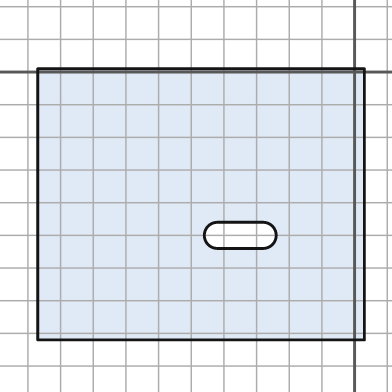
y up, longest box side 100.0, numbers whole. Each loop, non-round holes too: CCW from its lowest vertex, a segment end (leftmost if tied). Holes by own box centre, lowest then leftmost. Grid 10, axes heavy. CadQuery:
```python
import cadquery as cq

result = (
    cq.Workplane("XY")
    .moveTo(-97.0, -82.0)
    .lineTo(3.0, -82.0)
    .lineTo(3.0, 1.0)
    .lineTo(-97.0, 1.0)
    .close()
    .moveTo(-42.0, -54.0)
    .lineTo(-28.0, -54.0)
    .threePointArc((-24.0, -50.0), (-28.0, -46.0))
    .lineTo(-42.0, -46.0)
    .threePointArc((-46.0, -50.0), (-42.0, -54.0))
    .close()
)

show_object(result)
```